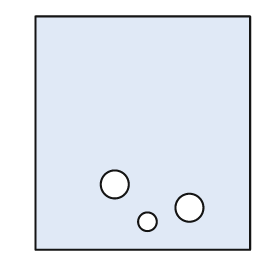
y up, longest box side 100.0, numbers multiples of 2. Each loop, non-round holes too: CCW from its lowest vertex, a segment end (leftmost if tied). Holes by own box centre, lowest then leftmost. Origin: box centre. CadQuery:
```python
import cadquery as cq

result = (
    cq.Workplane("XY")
    .moveTo(-46.0, -50.0)
    .lineTo(46.0, -50.0)
    .lineTo(46.0, 50.0)
    .lineTo(-46.0, 50.0)
    .close()
    .moveTo(2.0, -38.0)
    .circle(4.0)
    .moveTo(20.0, -32.0)
    .circle(6.0)
    .moveTo(-12.0, -22.0)
    .circle(6.0)
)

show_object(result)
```